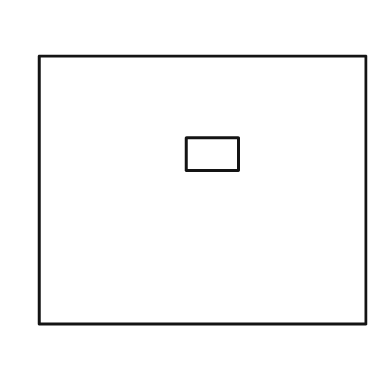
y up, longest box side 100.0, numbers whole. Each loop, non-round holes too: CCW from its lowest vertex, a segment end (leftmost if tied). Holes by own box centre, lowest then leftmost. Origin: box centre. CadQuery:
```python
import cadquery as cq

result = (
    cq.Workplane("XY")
    .moveTo(-50.0, -41.0)
    .lineTo(50.0, -41.0)
    .lineTo(50.0, 41.0)
    .lineTo(-50.0, 41.0)
    .close()
    .moveTo(-5.0, 6.0)
    .lineTo(11.0, 6.0)
    .lineTo(11.0, 16.0)
    .lineTo(-5.0, 16.0)
    .close()
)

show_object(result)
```